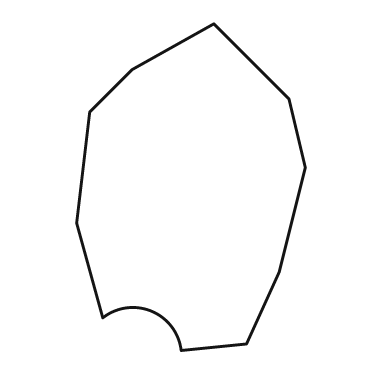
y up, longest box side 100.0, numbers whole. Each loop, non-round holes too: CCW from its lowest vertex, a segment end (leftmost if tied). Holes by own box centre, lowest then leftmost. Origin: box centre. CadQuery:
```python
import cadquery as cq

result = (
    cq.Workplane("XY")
    .moveTo(-3.0, -50.0)
    .lineTo(17.0, -48.0)
    .lineTo(27.0, -26.0)
    .lineTo(35.0, 6.0)
    .lineTo(30.0, 27.0)
    .lineTo(7.0, 50.0)
    .lineTo(-18.0, 36.0)
    .lineTo(-31.0, 23.0)
    .lineTo(-35.0, -11.0)
    .lineTo(-27.0, -40.0)
    .threePointArc((-12.0, -38.0), (-3.0, -50.0))
    .close()
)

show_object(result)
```